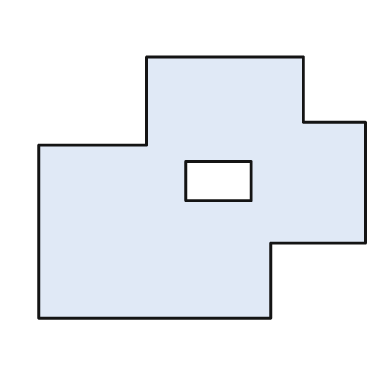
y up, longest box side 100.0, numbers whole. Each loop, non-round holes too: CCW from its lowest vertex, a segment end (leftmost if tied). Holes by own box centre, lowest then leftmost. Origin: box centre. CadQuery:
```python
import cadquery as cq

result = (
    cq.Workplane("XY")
    .moveTo(-50.0, -40.0)
    .lineTo(21.0, -40.0)
    .lineTo(21.0, -17.0)
    .lineTo(50.0, -17.0)
    .lineTo(50.0, 20.0)
    .lineTo(31.0, 20.0)
    .lineTo(31.0, 40.0)
    .lineTo(-17.0, 40.0)
    .lineTo(-17.0, 13.0)
    .lineTo(-50.0, 13.0)
    .close()
    .moveTo(-5.0, -4.0)
    .lineTo(15.0, -4.0)
    .lineTo(15.0, 8.0)
    .lineTo(-5.0, 8.0)
    .close()
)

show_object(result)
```